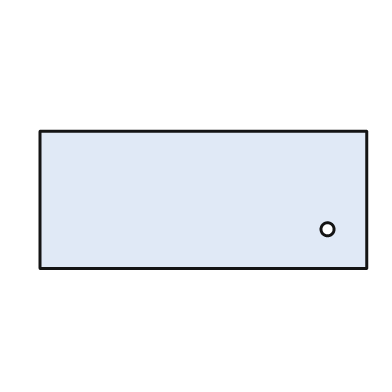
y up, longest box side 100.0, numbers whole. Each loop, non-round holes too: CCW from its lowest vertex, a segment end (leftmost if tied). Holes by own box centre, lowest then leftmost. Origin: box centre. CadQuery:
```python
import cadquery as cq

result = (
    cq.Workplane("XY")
    .moveTo(-50.0, -21.0)
    .lineTo(50.0, -21.0)
    .lineTo(50.0, 21.0)
    .lineTo(-50.0, 21.0)
    .close()
    .moveTo(38.0, -9.0)
    .circle(2.0)
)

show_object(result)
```